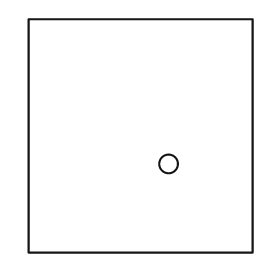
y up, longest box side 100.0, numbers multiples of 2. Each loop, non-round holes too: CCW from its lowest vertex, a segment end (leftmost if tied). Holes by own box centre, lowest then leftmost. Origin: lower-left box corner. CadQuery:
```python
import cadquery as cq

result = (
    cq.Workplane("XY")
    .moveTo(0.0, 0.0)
    .lineTo(96.0, 0.0)
    .lineTo(96.0, 100.0)
    .lineTo(0.0, 100.0)
    .close()
    .moveTo(60.0, 38.0)
    .circle(4.0)
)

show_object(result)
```